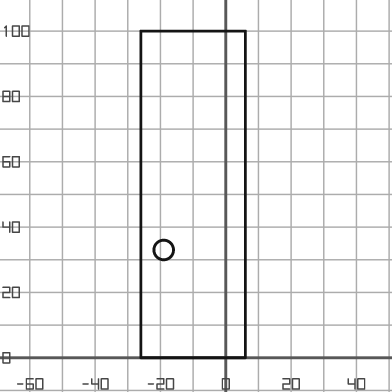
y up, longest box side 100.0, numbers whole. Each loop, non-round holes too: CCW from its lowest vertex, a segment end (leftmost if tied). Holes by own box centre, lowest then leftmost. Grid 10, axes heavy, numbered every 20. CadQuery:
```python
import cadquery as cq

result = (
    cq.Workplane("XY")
    .moveTo(-26.0, 0.0)
    .lineTo(6.0, 0.0)
    .lineTo(6.0, 100.0)
    .lineTo(-26.0, 100.0)
    .close()
    .moveTo(-19.0, 33.0)
    .circle(3.0)
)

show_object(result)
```